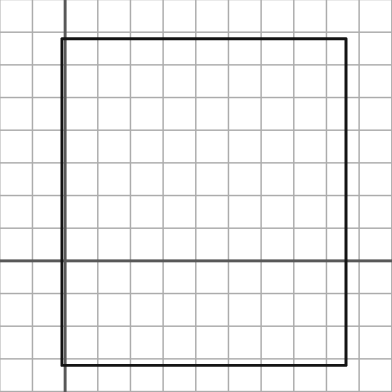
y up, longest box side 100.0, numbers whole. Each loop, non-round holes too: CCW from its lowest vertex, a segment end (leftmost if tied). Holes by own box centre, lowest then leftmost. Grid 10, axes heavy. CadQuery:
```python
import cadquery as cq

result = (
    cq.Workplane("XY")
    .moveTo(-1.0, -32.0)
    .lineTo(86.0, -32.0)
    .lineTo(86.0, 68.0)
    .lineTo(-1.0, 68.0)
    .close()
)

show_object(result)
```